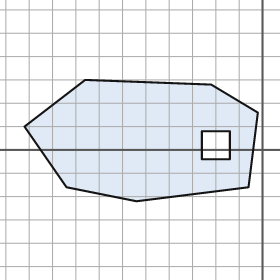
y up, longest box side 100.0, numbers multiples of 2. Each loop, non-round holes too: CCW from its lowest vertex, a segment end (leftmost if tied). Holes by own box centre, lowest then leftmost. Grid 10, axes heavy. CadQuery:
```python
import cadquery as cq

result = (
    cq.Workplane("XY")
    .moveTo(-54.0, -22.0)
    .lineTo(-6.0, -16.0)
    .lineTo(-2.0, 16.0)
    .lineTo(-22.0, 28.0)
    .lineTo(-76.0, 30.0)
    .lineTo(-102.0, 10.0)
    .lineTo(-84.0, -16.0)
    .close()
    .moveTo(-26.0, -4.0)
    .lineTo(-14.0, -4.0)
    .lineTo(-14.0, 8.0)
    .lineTo(-26.0, 8.0)
    .close()
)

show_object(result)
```